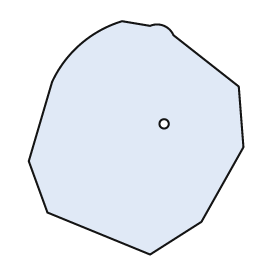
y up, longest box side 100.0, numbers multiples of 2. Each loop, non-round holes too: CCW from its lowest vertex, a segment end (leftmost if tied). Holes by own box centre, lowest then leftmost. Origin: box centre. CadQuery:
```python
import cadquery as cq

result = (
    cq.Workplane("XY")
    .moveTo(6.0, -50.0)
    .lineTo(28.0, -36.0)
    .lineTo(46.0, -4.0)
    .lineTo(44.0, 22.0)
    .lineTo(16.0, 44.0)
    .threePointArc((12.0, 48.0), (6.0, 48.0))
    .lineTo(-6.0, 50.0)
    .threePointArc((-24.0, 40.0), (-36.0, 24.0))
    .lineTo(-46.0, -10.0)
    .lineTo(-38.0, -32.0)
    .close()
    .moveTo(12.0, 6.0)
    .circle(2.0)
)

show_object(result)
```